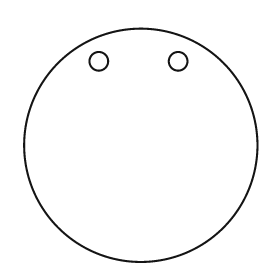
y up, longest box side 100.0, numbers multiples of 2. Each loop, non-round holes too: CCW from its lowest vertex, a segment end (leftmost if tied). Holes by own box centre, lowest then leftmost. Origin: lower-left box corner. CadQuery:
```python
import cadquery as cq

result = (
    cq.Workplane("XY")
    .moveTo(50.0, 50.0)
    .circle(50.0)
    .moveTo(32.0, 86.0)
    .circle(4.0)
    .moveTo(66.0, 86.0)
    .circle(4.0)
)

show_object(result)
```